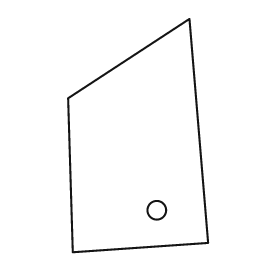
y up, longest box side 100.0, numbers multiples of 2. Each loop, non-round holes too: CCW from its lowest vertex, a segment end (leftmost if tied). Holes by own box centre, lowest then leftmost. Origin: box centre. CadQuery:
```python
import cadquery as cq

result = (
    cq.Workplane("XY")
    .moveTo(-28.0, -50.0)
    .lineTo(30.0, -46.0)
    .lineTo(22.0, 50.0)
    .lineTo(-30.0, 16.0)
    .close()
    .moveTo(8.0, -32.0)
    .circle(4.0)
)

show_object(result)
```